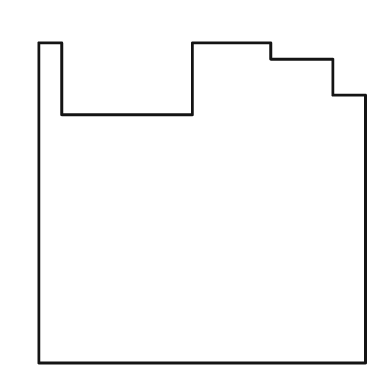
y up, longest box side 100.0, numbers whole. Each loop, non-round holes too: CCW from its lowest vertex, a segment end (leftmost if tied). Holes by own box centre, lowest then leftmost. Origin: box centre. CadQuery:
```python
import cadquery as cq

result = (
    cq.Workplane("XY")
    .moveTo(-50.0, -49.0)
    .lineTo(50.0, -49.0)
    .lineTo(50.0, 33.0)
    .lineTo(40.0, 33.0)
    .lineTo(40.0, 44.0)
    .lineTo(21.0, 44.0)
    .lineTo(21.0, 49.0)
    .lineTo(-3.0, 49.0)
    .lineTo(-3.0, 27.0)
    .lineTo(-43.0, 27.0)
    .lineTo(-43.0, 49.0)
    .lineTo(-50.0, 49.0)
    .close()
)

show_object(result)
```